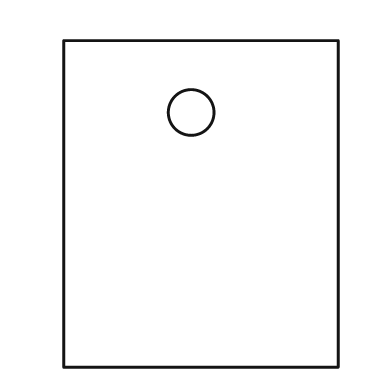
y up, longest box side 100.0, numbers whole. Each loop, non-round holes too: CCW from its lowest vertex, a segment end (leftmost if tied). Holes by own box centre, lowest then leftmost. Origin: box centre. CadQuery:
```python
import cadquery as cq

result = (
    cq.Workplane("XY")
    .moveTo(-42.0, -50.0)
    .lineTo(42.0, -50.0)
    .lineTo(42.0, 50.0)
    .lineTo(-42.0, 50.0)
    .close()
    .moveTo(-3.0, 28.0)
    .circle(7.0)
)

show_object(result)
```